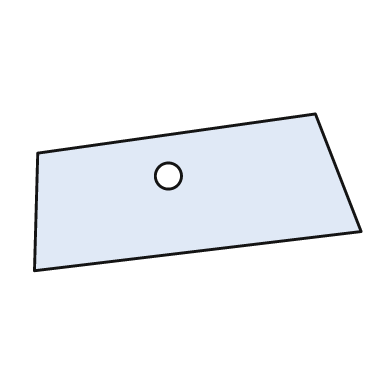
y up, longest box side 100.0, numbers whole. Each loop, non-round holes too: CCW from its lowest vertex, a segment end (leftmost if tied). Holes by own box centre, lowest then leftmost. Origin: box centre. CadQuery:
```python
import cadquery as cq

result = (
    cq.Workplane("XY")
    .moveTo(-50.0, -24.0)
    .lineTo(50.0, -12.0)
    .lineTo(36.0, 24.0)
    .lineTo(-49.0, 12.0)
    .close()
    .moveTo(-9.0, 5.0)
    .circle(4.0)
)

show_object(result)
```